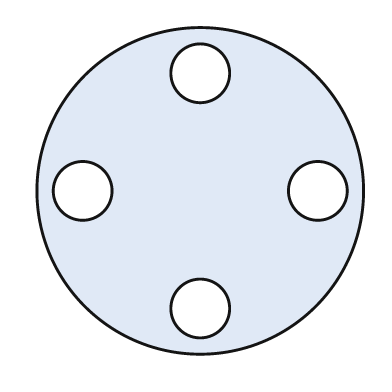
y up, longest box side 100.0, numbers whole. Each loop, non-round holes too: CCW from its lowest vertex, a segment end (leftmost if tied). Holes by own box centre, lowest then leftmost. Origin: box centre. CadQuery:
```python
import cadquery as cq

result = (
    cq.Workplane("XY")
    .moveTo(0.0, 0.0)
    .circle(50.0)
    .moveTo(0.0, -36.0)
    .circle(9.0)
    .moveTo(-36.0, 0.0)
    .circle(9.0)
    .moveTo(36.0, 0.0)
    .circle(9.0)
    .moveTo(0.0, 36.0)
    .circle(9.0)
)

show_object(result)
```